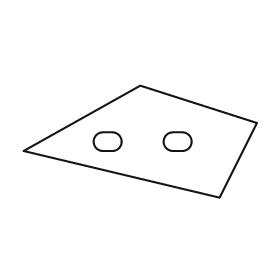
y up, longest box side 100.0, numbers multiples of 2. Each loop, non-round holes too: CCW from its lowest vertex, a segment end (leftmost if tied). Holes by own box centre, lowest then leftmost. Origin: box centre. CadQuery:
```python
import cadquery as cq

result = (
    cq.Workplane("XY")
    .moveTo(34.0, -24.0)
    .lineTo(50.0, 8.0)
    .lineTo(0.0, 24.0)
    .lineTo(-50.0, -4.0)
    .close()
    .moveTo(-16.0, -4.0)
    .lineTo(-12.0, -4.0)
    .threePointArc((-8.0, 0.0), (-12.0, 4.0))
    .lineTo(-16.0, 4.0)
    .threePointArc((-20.0, 0.0), (-16.0, -4.0))
    .close()
    .moveTo(14.0, -4.0)
    .lineTo(18.0, -4.0)
    .threePointArc((22.0, 0.0), (18.0, 4.0))
    .lineTo(14.0, 4.0)
    .threePointArc((10.0, 0.0), (14.0, -4.0))
    .close()
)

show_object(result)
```